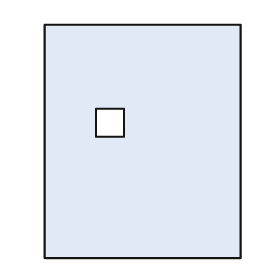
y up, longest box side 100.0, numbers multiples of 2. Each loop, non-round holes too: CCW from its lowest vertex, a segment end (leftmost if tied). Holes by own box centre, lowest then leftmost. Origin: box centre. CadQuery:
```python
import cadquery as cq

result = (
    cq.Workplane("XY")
    .moveTo(-42.0, -50.0)
    .lineTo(42.0, -50.0)
    .lineTo(42.0, 50.0)
    .lineTo(-42.0, 50.0)
    .close()
    .moveTo(-20.0, 2.0)
    .lineTo(-8.0, 2.0)
    .lineTo(-8.0, 14.0)
    .lineTo(-20.0, 14.0)
    .close()
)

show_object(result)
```